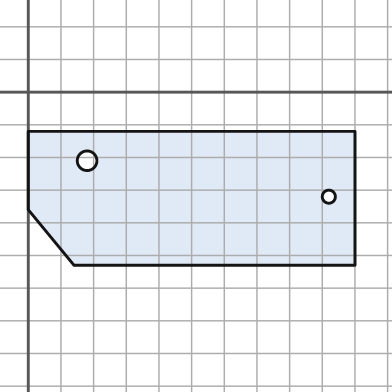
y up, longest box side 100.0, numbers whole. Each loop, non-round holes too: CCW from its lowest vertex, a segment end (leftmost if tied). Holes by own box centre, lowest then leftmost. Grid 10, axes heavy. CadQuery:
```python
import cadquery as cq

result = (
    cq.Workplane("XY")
    .moveTo(14.0, -53.0)
    .lineTo(100.0, -53.0)
    .lineTo(100.0, -12.0)
    .lineTo(0.0, -12.0)
    .lineTo(0.0, -36.0)
    .close()
    .moveTo(92.0, -32.0)
    .circle(2.0)
    .moveTo(18.0, -21.0)
    .circle(3.0)
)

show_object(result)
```